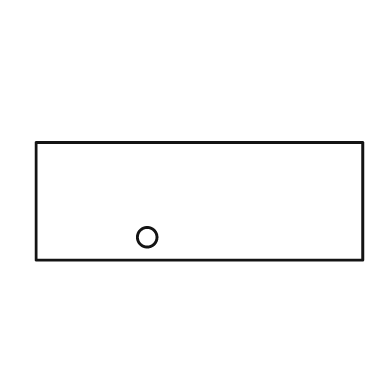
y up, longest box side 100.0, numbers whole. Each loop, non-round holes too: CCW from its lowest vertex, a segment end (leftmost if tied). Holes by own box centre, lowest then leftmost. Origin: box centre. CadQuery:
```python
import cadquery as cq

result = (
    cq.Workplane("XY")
    .moveTo(-50.0, -18.0)
    .lineTo(50.0, -18.0)
    .lineTo(50.0, 18.0)
    .lineTo(-50.0, 18.0)
    .close()
    .moveTo(-16.0, -11.0)
    .circle(3.0)
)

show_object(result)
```